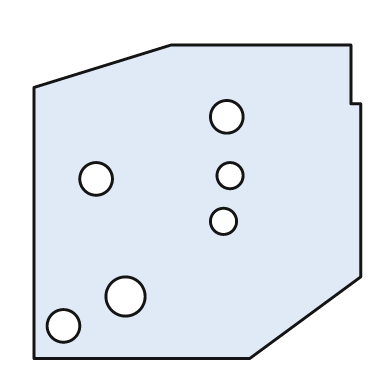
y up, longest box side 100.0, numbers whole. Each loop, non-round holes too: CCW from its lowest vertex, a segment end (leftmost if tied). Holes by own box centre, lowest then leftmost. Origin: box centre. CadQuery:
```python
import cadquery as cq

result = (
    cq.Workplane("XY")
    .moveTo(-50.0, -48.0)
    .lineTo(16.0, -48.0)
    .lineTo(50.0, -23.0)
    .lineTo(50.0, 30.0)
    .lineTo(47.0, 30.0)
    .lineTo(47.0, 48.0)
    .lineTo(-8.0, 48.0)
    .lineTo(-50.0, 35.0)
    .close()
    .moveTo(-41.0, -38.0)
    .circle(5.0)
    .moveTo(-22.0, -29.0)
    .circle(6.0)
    .moveTo(8.0, -6.0)
    .circle(4.0)
    .moveTo(-31.0, 7.0)
    .circle(5.0)
    .moveTo(10.0, 8.0)
    .circle(4.0)
    .moveTo(9.0, 26.0)
    .circle(5.0)
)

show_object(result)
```